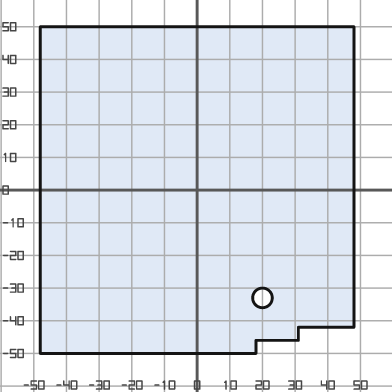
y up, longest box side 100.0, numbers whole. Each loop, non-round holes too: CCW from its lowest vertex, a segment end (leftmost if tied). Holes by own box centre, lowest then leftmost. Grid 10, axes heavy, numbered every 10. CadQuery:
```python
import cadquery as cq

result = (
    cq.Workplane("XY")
    .moveTo(-48.0, -50.0)
    .lineTo(18.0, -50.0)
    .lineTo(18.0, -46.0)
    .lineTo(31.0, -46.0)
    .lineTo(31.0, -42.0)
    .lineTo(48.0, -42.0)
    .lineTo(48.0, 50.0)
    .lineTo(-48.0, 50.0)
    .close()
    .moveTo(20.0, -33.0)
    .circle(3.0)
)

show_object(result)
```